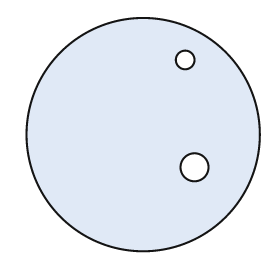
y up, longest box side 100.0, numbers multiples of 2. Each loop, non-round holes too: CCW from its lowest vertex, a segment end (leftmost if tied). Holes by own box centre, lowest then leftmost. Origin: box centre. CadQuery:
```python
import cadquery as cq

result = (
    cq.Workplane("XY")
    .moveTo(0.0, 0.0)
    .circle(50.0)
    .moveTo(22.0, -14.0)
    .circle(6.0)
    .moveTo(18.0, 32.0)
    .circle(4.0)
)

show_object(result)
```